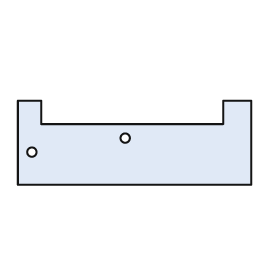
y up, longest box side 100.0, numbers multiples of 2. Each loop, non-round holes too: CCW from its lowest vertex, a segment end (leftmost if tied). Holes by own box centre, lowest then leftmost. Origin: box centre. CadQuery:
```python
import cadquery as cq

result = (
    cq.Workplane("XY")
    .moveTo(-50.0, -18.0)
    .lineTo(50.0, -18.0)
    .lineTo(50.0, 18.0)
    .lineTo(38.0, 18.0)
    .lineTo(38.0, 8.0)
    .lineTo(-40.0, 8.0)
    .lineTo(-40.0, 18.0)
    .lineTo(-50.0, 18.0)
    .close()
    .moveTo(-44.0, -4.0)
    .circle(2.0)
    .moveTo(-4.0, 2.0)
    .circle(2.0)
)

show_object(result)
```